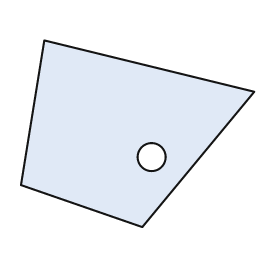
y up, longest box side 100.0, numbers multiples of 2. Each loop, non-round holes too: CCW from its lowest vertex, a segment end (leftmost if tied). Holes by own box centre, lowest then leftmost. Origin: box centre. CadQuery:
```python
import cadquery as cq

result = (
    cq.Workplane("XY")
    .moveTo(2.0, -40.0)
    .lineTo(50.0, 18.0)
    .lineTo(-40.0, 40.0)
    .lineTo(-50.0, -22.0)
    .close()
    .moveTo(6.0, -10.0)
    .circle(6.0)
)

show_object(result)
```